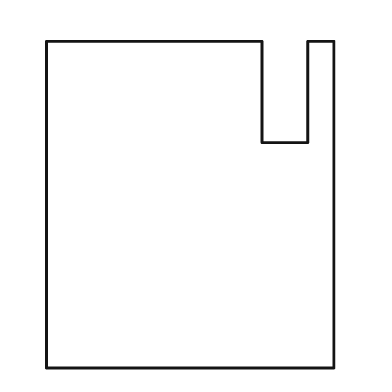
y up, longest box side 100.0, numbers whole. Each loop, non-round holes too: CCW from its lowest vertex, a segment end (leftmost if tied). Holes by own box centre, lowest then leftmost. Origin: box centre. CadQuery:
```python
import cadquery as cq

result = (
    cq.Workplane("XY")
    .moveTo(-44.0, -50.0)
    .lineTo(44.0, -50.0)
    .lineTo(44.0, 50.0)
    .lineTo(36.0, 50.0)
    .lineTo(36.0, 19.0)
    .lineTo(22.0, 19.0)
    .lineTo(22.0, 50.0)
    .lineTo(-44.0, 50.0)
    .close()
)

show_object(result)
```